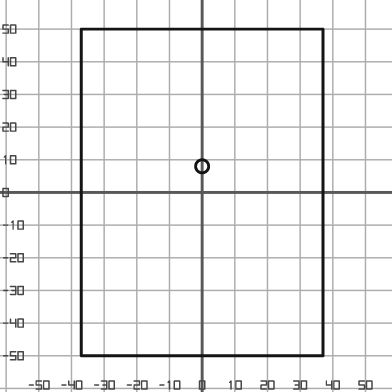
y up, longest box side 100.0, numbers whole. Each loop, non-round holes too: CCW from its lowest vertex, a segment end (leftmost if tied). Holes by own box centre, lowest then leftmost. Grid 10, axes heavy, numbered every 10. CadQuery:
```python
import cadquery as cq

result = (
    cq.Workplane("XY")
    .moveTo(-37.0, -50.0)
    .lineTo(37.0, -50.0)
    .lineTo(37.0, 50.0)
    .lineTo(-37.0, 50.0)
    .close()
    .moveTo(0.0, 8.0)
    .circle(2.0)
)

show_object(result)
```